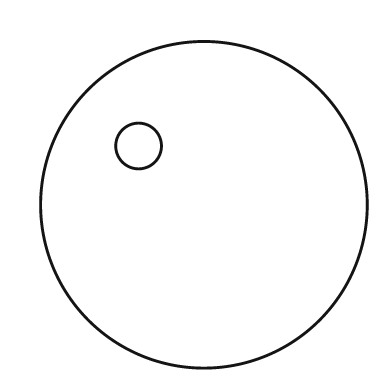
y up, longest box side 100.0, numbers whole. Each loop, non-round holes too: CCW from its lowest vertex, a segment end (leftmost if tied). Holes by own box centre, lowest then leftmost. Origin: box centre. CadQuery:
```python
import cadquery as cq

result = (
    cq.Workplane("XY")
    .moveTo(0.0, 0.0)
    .circle(50.0)
    .moveTo(-20.0, 18.0)
    .circle(7.0)
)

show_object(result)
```